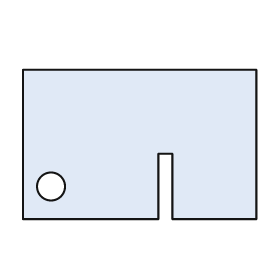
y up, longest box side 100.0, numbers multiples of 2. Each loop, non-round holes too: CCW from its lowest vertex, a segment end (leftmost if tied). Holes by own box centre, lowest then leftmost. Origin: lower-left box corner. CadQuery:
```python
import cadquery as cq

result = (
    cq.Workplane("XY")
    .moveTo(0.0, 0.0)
    .lineTo(58.0, 0.0)
    .lineTo(58.0, 28.0)
    .lineTo(64.0, 28.0)
    .lineTo(64.0, 0.0)
    .lineTo(100.0, 0.0)
    .lineTo(100.0, 64.0)
    .lineTo(0.0, 64.0)
    .close()
    .moveTo(12.0, 14.0)
    .circle(6.0)
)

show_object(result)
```